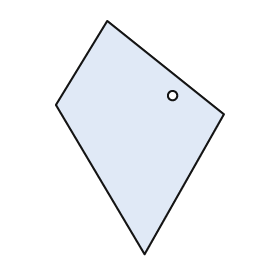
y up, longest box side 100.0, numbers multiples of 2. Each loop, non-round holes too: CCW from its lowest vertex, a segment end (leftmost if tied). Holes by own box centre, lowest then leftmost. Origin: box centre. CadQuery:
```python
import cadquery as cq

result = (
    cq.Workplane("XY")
    .moveTo(2.0, -50.0)
    .lineTo(36.0, 10.0)
    .lineTo(-14.0, 50.0)
    .lineTo(-36.0, 14.0)
    .close()
    .moveTo(14.0, 18.0)
    .circle(2.0)
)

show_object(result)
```